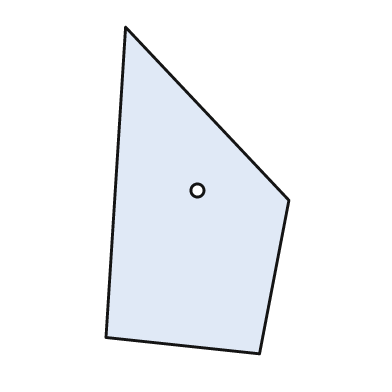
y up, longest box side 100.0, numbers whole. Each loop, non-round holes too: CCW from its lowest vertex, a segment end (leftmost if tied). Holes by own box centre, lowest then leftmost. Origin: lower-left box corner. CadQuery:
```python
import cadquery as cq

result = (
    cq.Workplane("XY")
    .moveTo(47.0, 0.0)
    .lineTo(56.0, 47.0)
    .lineTo(6.0, 100.0)
    .lineTo(0.0, 5.0)
    .close()
    .moveTo(28.0, 50.0)
    .circle(2.0)
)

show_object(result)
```